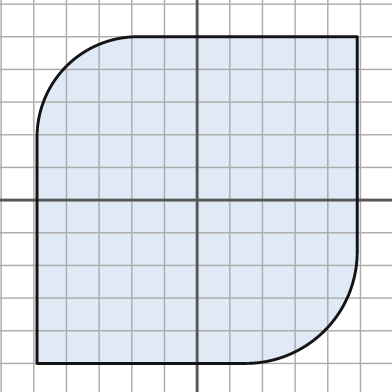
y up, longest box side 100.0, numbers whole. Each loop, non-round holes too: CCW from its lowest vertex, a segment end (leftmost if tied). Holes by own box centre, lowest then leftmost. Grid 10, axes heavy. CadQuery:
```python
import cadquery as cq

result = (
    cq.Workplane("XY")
    .moveTo(-49.0, -50.0)
    .lineTo(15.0, -50.0)
    .threePointArc((39.0, -40.0), (49.0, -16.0))
    .lineTo(49.0, 50.0)
    .lineTo(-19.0, 50.0)
    .threePointArc((-40.0, 41.0), (-49.0, 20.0))
    .close()
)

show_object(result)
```